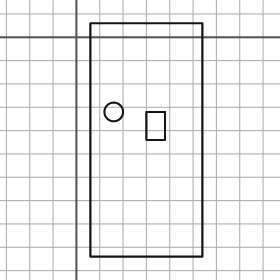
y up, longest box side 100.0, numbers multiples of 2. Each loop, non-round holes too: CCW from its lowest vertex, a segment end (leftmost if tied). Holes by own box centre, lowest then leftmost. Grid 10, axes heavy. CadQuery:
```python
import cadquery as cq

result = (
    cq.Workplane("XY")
    .moveTo(6.0, -94.0)
    .lineTo(54.0, -94.0)
    .lineTo(54.0, 6.0)
    .lineTo(6.0, 6.0)
    .close()
    .moveTo(30.0, -44.0)
    .lineTo(38.0, -44.0)
    .lineTo(38.0, -32.0)
    .lineTo(30.0, -32.0)
    .close()
    .moveTo(16.0, -32.0)
    .circle(4.0)
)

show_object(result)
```